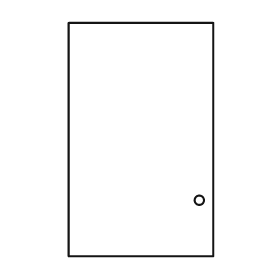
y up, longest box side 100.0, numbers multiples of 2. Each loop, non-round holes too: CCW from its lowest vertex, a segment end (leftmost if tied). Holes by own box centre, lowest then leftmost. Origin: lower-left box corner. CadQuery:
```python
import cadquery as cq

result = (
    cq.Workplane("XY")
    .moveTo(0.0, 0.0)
    .lineTo(62.0, 0.0)
    .lineTo(62.0, 100.0)
    .lineTo(0.0, 100.0)
    .close()
    .moveTo(56.0, 24.0)
    .circle(2.0)
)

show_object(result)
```